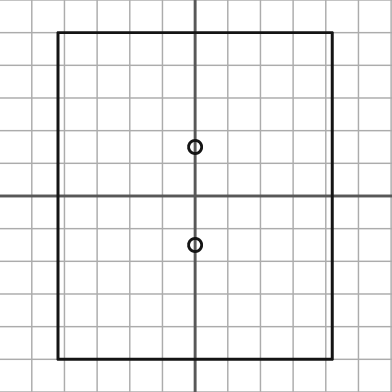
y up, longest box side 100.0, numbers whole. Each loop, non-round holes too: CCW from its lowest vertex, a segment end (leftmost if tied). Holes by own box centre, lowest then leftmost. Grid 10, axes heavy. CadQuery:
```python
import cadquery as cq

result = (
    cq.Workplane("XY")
    .moveTo(-42.0, -50.0)
    .lineTo(42.0, -50.0)
    .lineTo(42.0, 50.0)
    .lineTo(-42.0, 50.0)
    .close()
    .moveTo(0.0, -15.0)
    .circle(2.0)
    .moveTo(0.0, 15.0)
    .circle(2.0)
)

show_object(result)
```